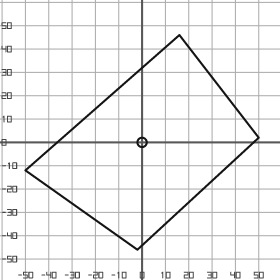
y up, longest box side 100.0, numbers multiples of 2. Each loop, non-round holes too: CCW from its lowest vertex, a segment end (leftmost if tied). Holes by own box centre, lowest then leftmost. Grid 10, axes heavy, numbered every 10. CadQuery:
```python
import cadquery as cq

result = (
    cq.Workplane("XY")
    .moveTo(-2.0, -46.0)
    .lineTo(50.0, 2.0)
    .lineTo(16.0, 46.0)
    .lineTo(-50.0, -12.0)
    .close()
    .moveTo(0.0, 0.0)
    .circle(2.0)
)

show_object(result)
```